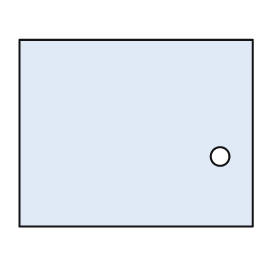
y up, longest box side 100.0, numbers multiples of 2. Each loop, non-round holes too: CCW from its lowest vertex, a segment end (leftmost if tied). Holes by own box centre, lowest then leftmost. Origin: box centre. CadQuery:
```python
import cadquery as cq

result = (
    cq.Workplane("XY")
    .moveTo(-50.0, -40.0)
    .lineTo(50.0, -40.0)
    .lineTo(50.0, 40.0)
    .lineTo(-50.0, 40.0)
    .close()
    .moveTo(36.0, -10.0)
    .circle(4.0)
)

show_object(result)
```